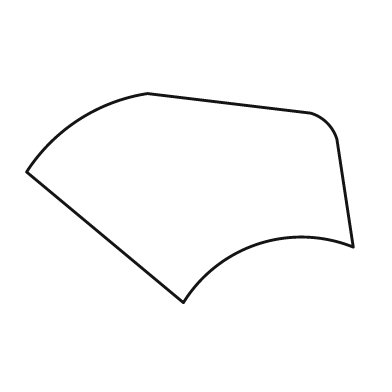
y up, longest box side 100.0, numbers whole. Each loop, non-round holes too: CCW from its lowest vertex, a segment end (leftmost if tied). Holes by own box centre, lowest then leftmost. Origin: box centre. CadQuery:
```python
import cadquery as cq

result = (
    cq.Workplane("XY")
    .moveTo(-2.0, -32.0)
    .threePointArc((21.0, -14.0), (50.0, -15.0))
    .lineTo(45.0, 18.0)
    .threePointArc((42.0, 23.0), (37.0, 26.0))
    .lineTo(-13.0, 32.0)
    .threePointArc((-34.0, 24.0), (-50.0, 8.0))
    .close()
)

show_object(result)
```